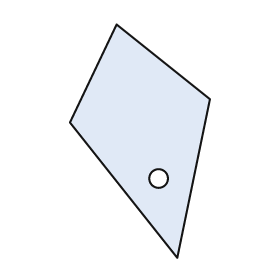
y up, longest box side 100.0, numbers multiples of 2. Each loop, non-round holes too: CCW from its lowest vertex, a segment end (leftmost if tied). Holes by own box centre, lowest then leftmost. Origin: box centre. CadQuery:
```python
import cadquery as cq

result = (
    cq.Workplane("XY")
    .moveTo(16.0, -50.0)
    .lineTo(30.0, 18.0)
    .lineTo(-10.0, 50.0)
    .lineTo(-30.0, 8.0)
    .close()
    .moveTo(8.0, -16.0)
    .circle(4.0)
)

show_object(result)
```